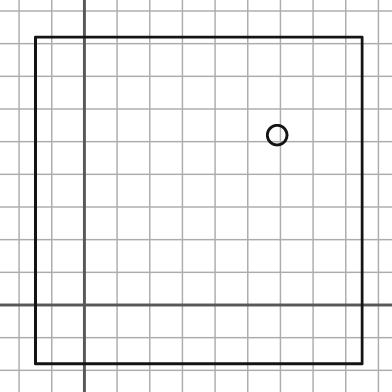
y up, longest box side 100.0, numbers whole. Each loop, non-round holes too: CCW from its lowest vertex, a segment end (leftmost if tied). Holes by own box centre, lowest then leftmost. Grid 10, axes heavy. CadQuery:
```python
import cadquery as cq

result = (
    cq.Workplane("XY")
    .moveTo(-15.0, -18.0)
    .lineTo(85.0, -18.0)
    .lineTo(85.0, 82.0)
    .lineTo(-15.0, 82.0)
    .close()
    .moveTo(59.0, 52.0)
    .circle(3.0)
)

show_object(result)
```